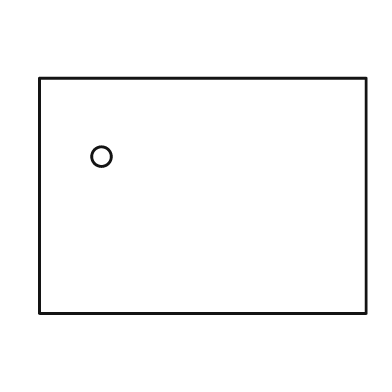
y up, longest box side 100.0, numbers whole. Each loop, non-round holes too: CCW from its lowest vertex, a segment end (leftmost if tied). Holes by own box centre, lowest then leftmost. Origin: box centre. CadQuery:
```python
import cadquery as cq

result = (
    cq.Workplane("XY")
    .moveTo(-50.0, -36.0)
    .lineTo(50.0, -36.0)
    .lineTo(50.0, 36.0)
    .lineTo(-50.0, 36.0)
    .close()
    .moveTo(-31.0, 12.0)
    .circle(3.0)
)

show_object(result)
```